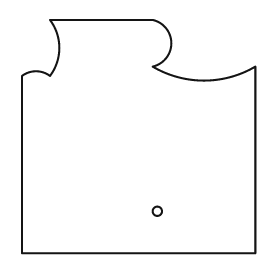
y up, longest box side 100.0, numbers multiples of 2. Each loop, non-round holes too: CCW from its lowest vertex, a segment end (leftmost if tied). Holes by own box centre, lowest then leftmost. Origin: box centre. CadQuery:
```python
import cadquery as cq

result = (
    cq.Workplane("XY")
    .moveTo(-50.0, -50.0)
    .lineTo(50.0, -50.0)
    .lineTo(50.0, 30.0)
    .threePointArc((28.0, 24.0), (6.0, 30.0))
    .threePointArc((14.0, 40.0), (6.0, 50.0))
    .lineTo(-38.0, 50.0)
    .threePointArc((-34.0, 38.0), (-38.0, 26.0))
    .threePointArc((-44.0, 28.0), (-50.0, 26.0))
    .close()
    .moveTo(8.0, -32.0)
    .circle(2.0)
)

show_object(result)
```